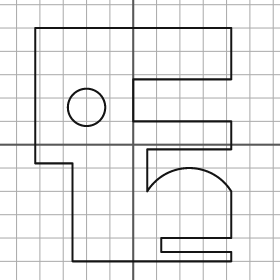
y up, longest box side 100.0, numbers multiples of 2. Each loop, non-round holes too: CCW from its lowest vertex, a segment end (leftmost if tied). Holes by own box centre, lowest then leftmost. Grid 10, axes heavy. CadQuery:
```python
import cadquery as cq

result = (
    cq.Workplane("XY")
    .moveTo(-26.0, -50.0)
    .lineTo(42.0, -50.0)
    .lineTo(42.0, -46.0)
    .lineTo(12.0, -46.0)
    .lineTo(12.0, -40.0)
    .lineTo(42.0, -40.0)
    .lineTo(42.0, -20.0)
    .threePointArc((24.0, -10.0), (6.0, -20.0))
    .lineTo(6.0, -2.0)
    .lineTo(42.0, -2.0)
    .lineTo(42.0, 10.0)
    .lineTo(0.0, 10.0)
    .lineTo(0.0, 28.0)
    .lineTo(42.0, 28.0)
    .lineTo(42.0, 50.0)
    .lineTo(-42.0, 50.0)
    .lineTo(-42.0, -8.0)
    .lineTo(-26.0, -8.0)
    .close()
    .moveTo(-20.0, 16.0)
    .circle(8.0)
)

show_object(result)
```